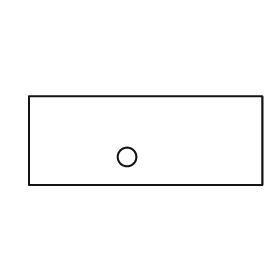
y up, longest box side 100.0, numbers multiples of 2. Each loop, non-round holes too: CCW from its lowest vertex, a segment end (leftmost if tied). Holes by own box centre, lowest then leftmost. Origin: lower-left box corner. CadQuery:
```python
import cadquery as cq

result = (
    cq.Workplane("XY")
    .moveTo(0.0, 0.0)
    .lineTo(100.0, 0.0)
    .lineTo(100.0, 38.0)
    .lineTo(0.0, 38.0)
    .close()
    .moveTo(42.0, 12.0)
    .circle(4.0)
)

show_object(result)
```